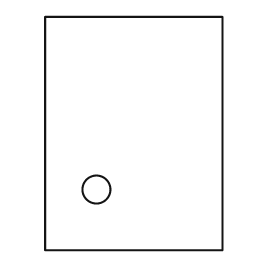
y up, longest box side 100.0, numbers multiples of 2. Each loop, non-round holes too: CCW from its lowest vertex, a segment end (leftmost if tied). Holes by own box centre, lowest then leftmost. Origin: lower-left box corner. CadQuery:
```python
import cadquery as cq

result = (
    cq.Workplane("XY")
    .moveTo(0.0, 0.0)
    .lineTo(76.0, 0.0)
    .lineTo(76.0, 100.0)
    .lineTo(0.0, 100.0)
    .close()
    .moveTo(22.0, 26.0)
    .circle(6.0)
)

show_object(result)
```